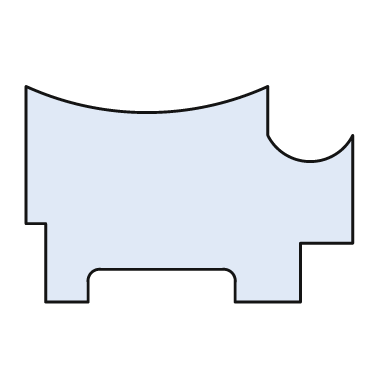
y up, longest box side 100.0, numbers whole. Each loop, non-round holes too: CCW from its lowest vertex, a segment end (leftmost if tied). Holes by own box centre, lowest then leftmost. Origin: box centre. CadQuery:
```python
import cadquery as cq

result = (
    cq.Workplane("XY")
    .moveTo(-44.0, -33.0)
    .lineTo(-31.0, -33.0)
    .lineTo(-31.0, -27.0)
    .threePointArc((-30.0, -24.0), (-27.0, -23.0))
    .lineTo(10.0, -23.0)
    .threePointArc((13.0, -24.0), (14.0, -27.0))
    .lineTo(14.0, -33.0)
    .lineTo(34.0, -33.0)
    .lineTo(34.0, -15.0)
    .lineTo(50.0, -15.0)
    .lineTo(50.0, 18.0)
    .threePointArc((37.0, 10.0), (24.0, 18.0))
    .lineTo(24.0, 33.0)
    .threePointArc((-13.0, 25.0), (-50.0, 33.0))
    .lineTo(-50.0, -9.0)
    .lineTo(-44.0, -9.0)
    .close()
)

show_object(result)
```